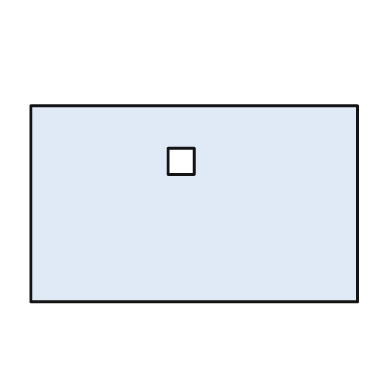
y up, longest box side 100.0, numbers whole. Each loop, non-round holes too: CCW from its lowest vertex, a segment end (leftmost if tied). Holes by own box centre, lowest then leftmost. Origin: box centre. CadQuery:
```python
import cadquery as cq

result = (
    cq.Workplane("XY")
    .moveTo(-50.0, -30.0)
    .lineTo(50.0, -30.0)
    .lineTo(50.0, 30.0)
    .lineTo(-50.0, 30.0)
    .close()
    .moveTo(-8.0, 9.0)
    .lineTo(0.0, 9.0)
    .lineTo(0.0, 17.0)
    .lineTo(-8.0, 17.0)
    .close()
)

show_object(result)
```